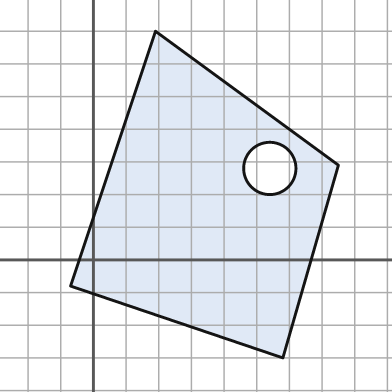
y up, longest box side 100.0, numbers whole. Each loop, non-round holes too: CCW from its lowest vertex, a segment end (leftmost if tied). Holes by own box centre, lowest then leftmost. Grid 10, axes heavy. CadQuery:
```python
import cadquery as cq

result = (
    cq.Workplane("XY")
    .moveTo(58.0, -30.0)
    .lineTo(75.0, 29.0)
    .lineTo(19.0, 70.0)
    .lineTo(-7.0, -8.0)
    .close()
    .moveTo(54.0, 28.0)
    .circle(8.0)
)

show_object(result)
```